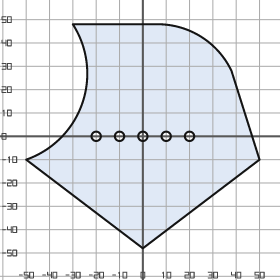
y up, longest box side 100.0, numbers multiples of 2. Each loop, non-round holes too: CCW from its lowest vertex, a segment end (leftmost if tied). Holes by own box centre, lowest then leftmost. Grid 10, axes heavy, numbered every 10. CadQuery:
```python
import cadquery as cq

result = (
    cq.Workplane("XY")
    .moveTo(0.0, -48.0)
    .lineTo(50.0, -10.0)
    .lineTo(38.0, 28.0)
    .threePointArc((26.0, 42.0), (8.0, 48.0))
    .lineTo(-30.0, 48.0)
    .threePointArc((-26.0, 14.0), (-50.0, -10.0))
    .close()
    .moveTo(-20.0, 0.0)
    .circle(2.0)
    .moveTo(-10.0, 0.0)
    .circle(2.0)
    .moveTo(0.0, 0.0)
    .circle(2.0)
    .moveTo(10.0, 0.0)
    .circle(2.0)
    .moveTo(20.0, 0.0)
    .circle(2.0)
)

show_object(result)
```